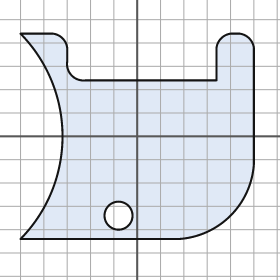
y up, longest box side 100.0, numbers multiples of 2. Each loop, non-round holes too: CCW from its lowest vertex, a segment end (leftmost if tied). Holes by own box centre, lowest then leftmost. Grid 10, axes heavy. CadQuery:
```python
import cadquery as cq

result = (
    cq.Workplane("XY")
    .moveTo(-50.0, -44.0)
    .lineTo(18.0, -44.0)
    .threePointArc((40.0, -34.0), (50.0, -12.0))
    .lineTo(50.0, 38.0)
    .threePointArc((48.0, 42.0), (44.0, 44.0))
    .lineTo(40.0, 44.0)
    .threePointArc((36.0, 42.0), (34.0, 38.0))
    .lineTo(34.0, 24.0)
    .lineTo(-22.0, 24.0)
    .threePointArc((-28.0, 26.0), (-30.0, 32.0))
    .lineTo(-30.0, 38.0)
    .threePointArc((-32.0, 42.0), (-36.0, 44.0))
    .lineTo(-50.0, 44.0)
    .threePointArc((-32.0, 0.0), (-50.0, -44.0))
    .close()
    .moveTo(-8.0, -34.0)
    .circle(6.0)
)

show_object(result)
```